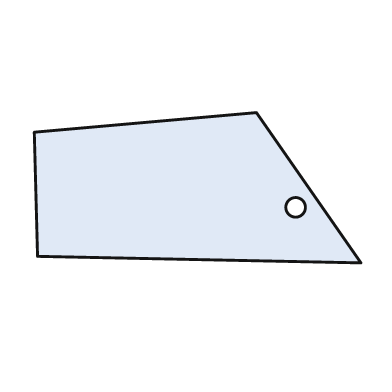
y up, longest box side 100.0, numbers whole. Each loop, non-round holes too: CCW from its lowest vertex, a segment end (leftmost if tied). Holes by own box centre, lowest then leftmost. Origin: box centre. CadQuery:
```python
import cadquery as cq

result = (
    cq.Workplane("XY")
    .moveTo(50.0, -23.0)
    .lineTo(18.0, 23.0)
    .lineTo(-50.0, 17.0)
    .lineTo(-49.0, -21.0)
    .close()
    .moveTo(30.0, -6.0)
    .circle(3.0)
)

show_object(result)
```